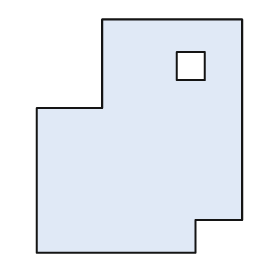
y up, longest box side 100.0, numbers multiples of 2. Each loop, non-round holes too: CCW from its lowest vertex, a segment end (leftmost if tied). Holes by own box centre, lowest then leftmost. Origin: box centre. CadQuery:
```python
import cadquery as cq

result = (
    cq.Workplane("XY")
    .moveTo(-44.0, -50.0)
    .lineTo(24.0, -50.0)
    .lineTo(24.0, -36.0)
    .lineTo(44.0, -36.0)
    .lineTo(44.0, 50.0)
    .lineTo(-16.0, 50.0)
    .lineTo(-16.0, 12.0)
    .lineTo(-44.0, 12.0)
    .close()
    .moveTo(16.0, 24.0)
    .lineTo(28.0, 24.0)
    .lineTo(28.0, 36.0)
    .lineTo(16.0, 36.0)
    .close()
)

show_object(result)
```